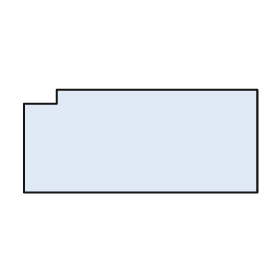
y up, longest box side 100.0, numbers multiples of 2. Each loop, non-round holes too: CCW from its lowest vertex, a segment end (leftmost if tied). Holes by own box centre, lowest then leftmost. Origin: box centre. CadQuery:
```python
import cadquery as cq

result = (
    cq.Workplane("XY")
    .moveTo(-50.0, -22.0)
    .lineTo(50.0, -22.0)
    .lineTo(50.0, 22.0)
    .lineTo(-36.0, 22.0)
    .lineTo(-36.0, 16.0)
    .lineTo(-50.0, 16.0)
    .close()
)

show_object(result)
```